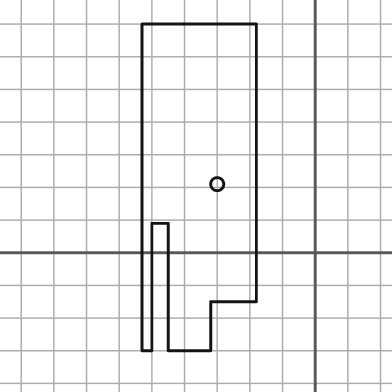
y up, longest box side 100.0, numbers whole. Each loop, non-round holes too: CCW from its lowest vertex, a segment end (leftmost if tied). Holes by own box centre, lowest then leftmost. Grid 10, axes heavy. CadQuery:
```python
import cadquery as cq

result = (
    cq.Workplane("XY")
    .moveTo(-53.0, -30.0)
    .lineTo(-50.0, -30.0)
    .lineTo(-50.0, 9.0)
    .lineTo(-45.0, 9.0)
    .lineTo(-45.0, -30.0)
    .lineTo(-32.0, -30.0)
    .lineTo(-32.0, -15.0)
    .lineTo(-18.0, -15.0)
    .lineTo(-18.0, 70.0)
    .lineTo(-53.0, 70.0)
    .close()
    .moveTo(-30.0, 21.0)
    .circle(2.0)
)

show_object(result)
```